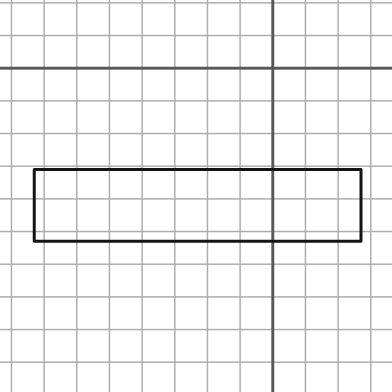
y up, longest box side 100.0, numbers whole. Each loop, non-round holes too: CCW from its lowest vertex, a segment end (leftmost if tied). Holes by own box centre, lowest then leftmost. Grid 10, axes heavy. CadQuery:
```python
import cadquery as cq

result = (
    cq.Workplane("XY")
    .moveTo(-73.0, -53.0)
    .lineTo(27.0, -53.0)
    .lineTo(27.0, -31.0)
    .lineTo(-73.0, -31.0)
    .close()
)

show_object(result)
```